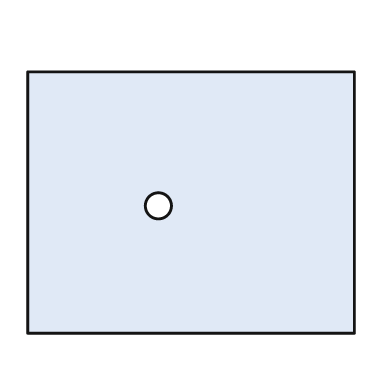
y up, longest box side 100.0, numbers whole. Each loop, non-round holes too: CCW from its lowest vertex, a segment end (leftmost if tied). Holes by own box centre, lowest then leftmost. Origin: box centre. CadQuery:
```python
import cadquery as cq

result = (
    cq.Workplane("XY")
    .moveTo(-50.0, -40.0)
    .lineTo(50.0, -40.0)
    .lineTo(50.0, 40.0)
    .lineTo(-50.0, 40.0)
    .close()
    .moveTo(-10.0, -1.0)
    .circle(4.0)
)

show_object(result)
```